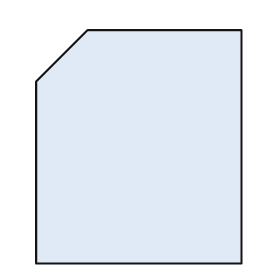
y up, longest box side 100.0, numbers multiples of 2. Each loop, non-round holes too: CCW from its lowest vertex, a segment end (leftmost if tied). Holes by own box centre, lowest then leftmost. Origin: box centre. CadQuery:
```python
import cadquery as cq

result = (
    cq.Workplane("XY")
    .moveTo(-44.0, -50.0)
    .lineTo(44.0, -50.0)
    .lineTo(44.0, 50.0)
    .lineTo(-22.0, 50.0)
    .lineTo(-44.0, 28.0)
    .close()
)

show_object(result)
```